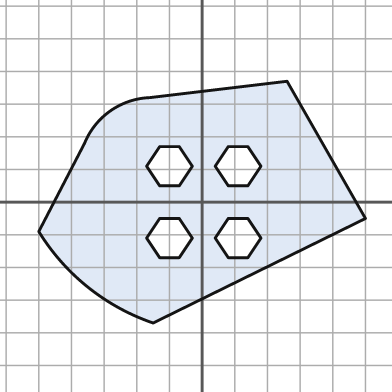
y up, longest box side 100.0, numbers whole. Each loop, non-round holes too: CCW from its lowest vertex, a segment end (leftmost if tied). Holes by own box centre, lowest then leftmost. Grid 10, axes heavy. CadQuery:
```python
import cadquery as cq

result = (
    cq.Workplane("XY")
    .moveTo(-15.0, -37.0)
    .lineTo(50.0, -5.0)
    .lineTo(26.0, 37.0)
    .lineTo(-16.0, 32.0)
    .threePointArc((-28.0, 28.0), (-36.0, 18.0))
    .lineTo(-50.0, -9.0)
    .threePointArc((-35.0, -26.0), (-15.0, -37.0))
    .close()
    .moveTo(-13.0, -17.0)
    .lineTo(-7.0, -17.0)
    .lineTo(-3.0, -11.0)
    .lineTo(-7.0, -5.0)
    .lineTo(-13.0, -5.0)
    .lineTo(-17.0, -11.0)
    .close()
    .moveTo(8.0, -17.0)
    .lineTo(14.0, -17.0)
    .lineTo(18.0, -11.0)
    .lineTo(14.0, -5.0)
    .lineTo(8.0, -5.0)
    .lineTo(4.0, -11.0)
    .close()
    .moveTo(-13.0, 5.0)
    .lineTo(-7.0, 5.0)
    .lineTo(-3.0, 11.0)
    .lineTo(-7.0, 17.0)
    .lineTo(-13.0, 17.0)
    .lineTo(-17.0, 11.0)
    .close()
    .moveTo(8.0, 5.0)
    .lineTo(14.0, 5.0)
    .lineTo(18.0, 11.0)
    .lineTo(14.0, 17.0)
    .lineTo(8.0, 17.0)
    .lineTo(4.0, 11.0)
    .close()
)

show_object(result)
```